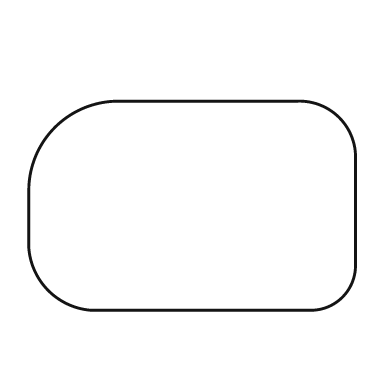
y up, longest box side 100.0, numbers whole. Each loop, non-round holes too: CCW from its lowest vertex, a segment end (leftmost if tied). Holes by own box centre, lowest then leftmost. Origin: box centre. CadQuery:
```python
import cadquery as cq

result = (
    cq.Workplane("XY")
    .moveTo(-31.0, -32.0)
    .lineTo(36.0, -32.0)
    .threePointArc((46.0, -28.0), (50.0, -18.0))
    .lineTo(50.0, 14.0)
    .threePointArc((45.0, 27.0), (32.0, 32.0))
    .lineTo(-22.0, 32.0)
    .threePointArc((-42.0, 24.0), (-50.0, 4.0))
    .lineTo(-50.0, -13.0)
    .threePointArc((-44.0, -26.0), (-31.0, -32.0))
    .close()
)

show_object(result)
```